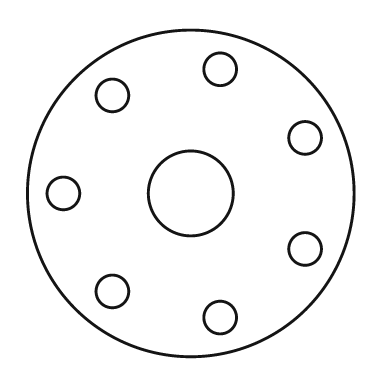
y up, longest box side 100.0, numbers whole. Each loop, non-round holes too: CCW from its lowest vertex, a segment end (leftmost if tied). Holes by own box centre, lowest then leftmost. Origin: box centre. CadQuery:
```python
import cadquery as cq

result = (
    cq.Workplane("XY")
    .moveTo(0.0, 0.0)
    .circle(50.0)
    .moveTo(9.0, -38.0)
    .circle(5.0)
    .moveTo(-24.0, -30.0)
    .circle(5.0)
    .moveTo(35.0, -17.0)
    .circle(5.0)
    .moveTo(-39.0, 0.0)
    .circle(5.0)
    .moveTo(0.0, 0.0)
    .circle(13.0)
    .moveTo(35.0, 17.0)
    .circle(5.0)
    .moveTo(-24.0, 30.0)
    .circle(5.0)
    .moveTo(9.0, 38.0)
    .circle(5.0)
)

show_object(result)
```